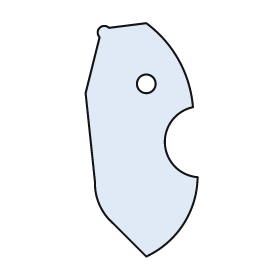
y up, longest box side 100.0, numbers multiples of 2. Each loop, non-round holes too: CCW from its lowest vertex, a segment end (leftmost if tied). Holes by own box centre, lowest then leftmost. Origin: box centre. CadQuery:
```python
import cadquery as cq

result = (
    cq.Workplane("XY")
    .moveTo(2.0, -50.0)
    .threePointArc((18.0, -36.0), (24.0, -16.0))
    .threePointArc((10.0, -2.0), (22.0, 14.0))
    .threePointArc((16.0, 34.0), (2.0, 50.0))
    .lineTo(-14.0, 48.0)
    .threePointArc((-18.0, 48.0), (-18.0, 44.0))
    .lineTo(-24.0, 20.0)
    .lineTo(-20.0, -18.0)
    .threePointArc((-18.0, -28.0), (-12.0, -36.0))
    .close()
    .moveTo(2.0, 24.0)
    .circle(4.0)
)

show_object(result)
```